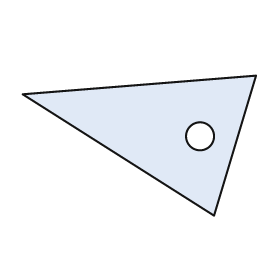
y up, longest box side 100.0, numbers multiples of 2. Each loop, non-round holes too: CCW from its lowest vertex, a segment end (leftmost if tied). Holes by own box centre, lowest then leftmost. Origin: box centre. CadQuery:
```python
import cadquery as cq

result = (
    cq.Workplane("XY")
    .moveTo(32.0, -30.0)
    .lineTo(50.0, 30.0)
    .lineTo(-50.0, 22.0)
    .close()
    .moveTo(26.0, 4.0)
    .circle(6.0)
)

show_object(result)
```